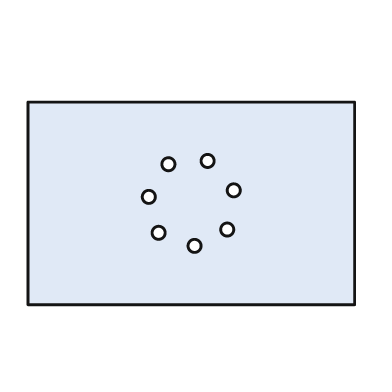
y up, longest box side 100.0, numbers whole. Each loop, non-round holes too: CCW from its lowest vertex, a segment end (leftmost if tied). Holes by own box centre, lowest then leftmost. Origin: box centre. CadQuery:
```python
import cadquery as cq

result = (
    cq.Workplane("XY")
    .moveTo(-50.0, -31.0)
    .lineTo(50.0, -31.0)
    .lineTo(50.0, 31.0)
    .lineTo(-50.0, 31.0)
    .close()
    .moveTo(1.0, -13.0)
    .circle(2.0)
    .moveTo(-10.0, -9.0)
    .circle(2.0)
    .moveTo(11.0, -8.0)
    .circle(2.0)
    .moveTo(-13.0, 2.0)
    .circle(2.0)
    .moveTo(13.0, 4.0)
    .circle(2.0)
    .moveTo(-7.0, 12.0)
    .circle(2.0)
    .moveTo(5.0, 13.0)
    .circle(2.0)
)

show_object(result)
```